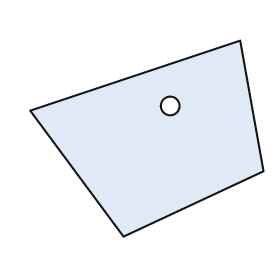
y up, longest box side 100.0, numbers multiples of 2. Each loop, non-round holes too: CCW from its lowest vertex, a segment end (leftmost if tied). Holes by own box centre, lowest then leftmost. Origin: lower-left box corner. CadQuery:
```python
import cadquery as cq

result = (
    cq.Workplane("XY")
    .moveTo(40.0, 0.0)
    .lineTo(100.0, 28.0)
    .lineTo(90.0, 84.0)
    .lineTo(0.0, 54.0)
    .close()
    .moveTo(60.0, 56.0)
    .circle(4.0)
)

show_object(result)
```